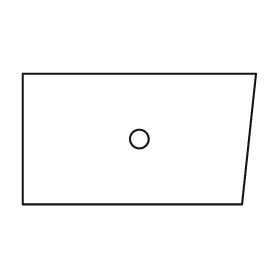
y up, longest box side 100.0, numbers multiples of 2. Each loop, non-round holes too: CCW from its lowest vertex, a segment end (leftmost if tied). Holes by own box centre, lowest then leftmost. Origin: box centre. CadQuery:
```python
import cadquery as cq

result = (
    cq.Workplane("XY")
    .moveTo(-50.0, -28.0)
    .lineTo(44.0, -28.0)
    .lineTo(50.0, 28.0)
    .lineTo(-50.0, 28.0)
    .close()
    .moveTo(0.0, 0.0)
    .circle(4.0)
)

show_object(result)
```